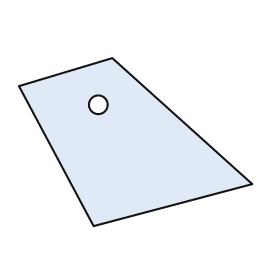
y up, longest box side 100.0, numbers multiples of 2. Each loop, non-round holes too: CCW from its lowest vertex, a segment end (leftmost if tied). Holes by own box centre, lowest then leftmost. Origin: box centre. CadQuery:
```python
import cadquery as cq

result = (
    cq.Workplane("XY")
    .moveTo(-18.0, -36.0)
    .lineTo(50.0, -18.0)
    .lineTo(-10.0, 36.0)
    .lineTo(-50.0, 24.0)
    .close()
    .moveTo(-16.0, 16.0)
    .circle(4.0)
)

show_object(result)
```